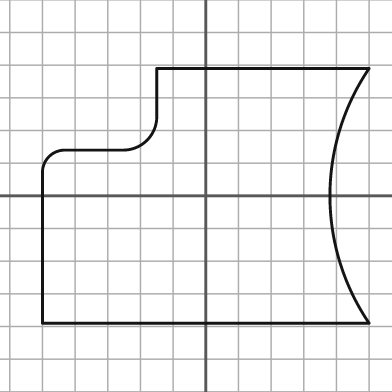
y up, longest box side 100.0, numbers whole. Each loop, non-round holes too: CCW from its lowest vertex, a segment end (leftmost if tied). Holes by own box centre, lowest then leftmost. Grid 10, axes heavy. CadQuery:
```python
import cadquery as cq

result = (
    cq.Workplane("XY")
    .moveTo(-50.0, -39.0)
    .lineTo(50.0, -39.0)
    .threePointArc((38.0, 0.0), (50.0, 39.0))
    .lineTo(-15.0, 39.0)
    .lineTo(-15.0, 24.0)
    .threePointArc((-18.0, 17.0), (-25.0, 14.0))
    .lineTo(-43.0, 14.0)
    .threePointArc((-48.0, 12.0), (-50.0, 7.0))
    .close()
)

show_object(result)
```